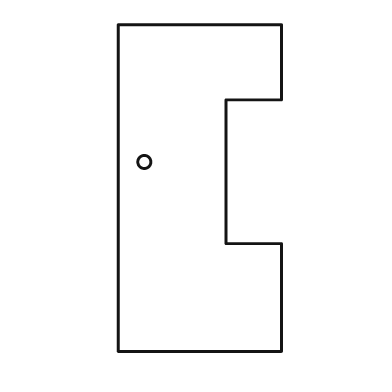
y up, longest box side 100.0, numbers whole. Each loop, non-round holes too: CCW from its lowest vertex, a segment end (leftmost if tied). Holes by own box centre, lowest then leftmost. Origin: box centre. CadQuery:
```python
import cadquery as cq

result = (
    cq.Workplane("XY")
    .moveTo(-25.0, -50.0)
    .lineTo(25.0, -50.0)
    .lineTo(25.0, -17.0)
    .lineTo(8.0, -17.0)
    .lineTo(8.0, 27.0)
    .lineTo(25.0, 27.0)
    .lineTo(25.0, 50.0)
    .lineTo(-25.0, 50.0)
    .close()
    .moveTo(-17.0, 8.0)
    .circle(2.0)
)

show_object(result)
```